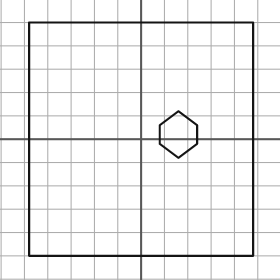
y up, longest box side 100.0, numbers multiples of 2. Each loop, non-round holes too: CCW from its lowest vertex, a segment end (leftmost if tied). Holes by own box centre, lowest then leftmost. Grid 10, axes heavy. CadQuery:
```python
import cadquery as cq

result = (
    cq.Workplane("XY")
    .moveTo(-48.0, -50.0)
    .lineTo(48.0, -50.0)
    .lineTo(48.0, 50.0)
    .lineTo(-48.0, 50.0)
    .close()
    .moveTo(16.0, -8.0)
    .lineTo(24.0, -2.0)
    .lineTo(24.0, 6.0)
    .lineTo(16.0, 12.0)
    .lineTo(8.0, 6.0)
    .lineTo(8.0, -2.0)
    .close()
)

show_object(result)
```